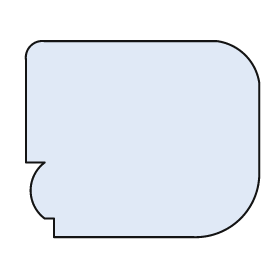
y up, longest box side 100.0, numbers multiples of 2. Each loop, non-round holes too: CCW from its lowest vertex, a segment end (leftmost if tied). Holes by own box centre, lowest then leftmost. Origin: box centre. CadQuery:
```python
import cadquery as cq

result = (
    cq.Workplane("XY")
    .moveTo(-38.0, -42.0)
    .lineTo(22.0, -42.0)
    .threePointArc((42.0, -34.0), (50.0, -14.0))
    .lineTo(50.0, 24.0)
    .threePointArc((44.0, 36.0), (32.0, 42.0))
    .lineTo(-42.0, 42.0)
    .threePointArc((-48.0, 40.0), (-50.0, 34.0))
    .lineTo(-50.0, -10.0)
    .lineTo(-42.0, -10.0)
    .threePointArc((-48.0, -22.0), (-42.0, -34.0))
    .lineTo(-38.0, -34.0)
    .close()
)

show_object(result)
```